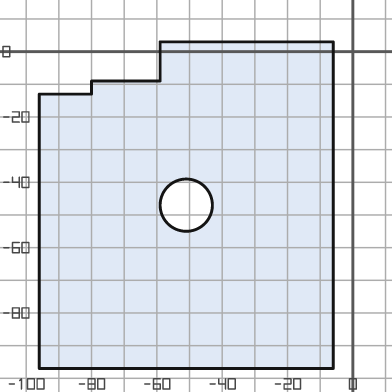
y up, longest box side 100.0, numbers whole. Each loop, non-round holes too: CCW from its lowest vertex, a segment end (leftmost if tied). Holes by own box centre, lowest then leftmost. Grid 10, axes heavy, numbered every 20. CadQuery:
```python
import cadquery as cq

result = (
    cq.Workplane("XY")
    .moveTo(-96.0, -97.0)
    .lineTo(-6.0, -97.0)
    .lineTo(-6.0, 3.0)
    .lineTo(-59.0, 3.0)
    .lineTo(-59.0, -9.0)
    .lineTo(-80.0, -9.0)
    .lineTo(-80.0, -13.0)
    .lineTo(-96.0, -13.0)
    .close()
    .moveTo(-51.0, -47.0)
    .circle(8.0)
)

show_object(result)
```